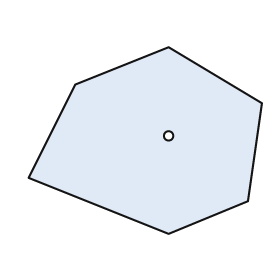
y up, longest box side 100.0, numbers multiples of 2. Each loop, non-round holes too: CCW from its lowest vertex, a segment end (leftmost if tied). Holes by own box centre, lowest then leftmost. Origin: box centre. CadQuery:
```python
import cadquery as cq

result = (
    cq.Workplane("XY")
    .moveTo(10.0, -40.0)
    .lineTo(44.0, -26.0)
    .lineTo(50.0, 16.0)
    .lineTo(10.0, 40.0)
    .lineTo(-30.0, 24.0)
    .lineTo(-50.0, -16.0)
    .close()
    .moveTo(10.0, 2.0)
    .circle(2.0)
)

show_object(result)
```